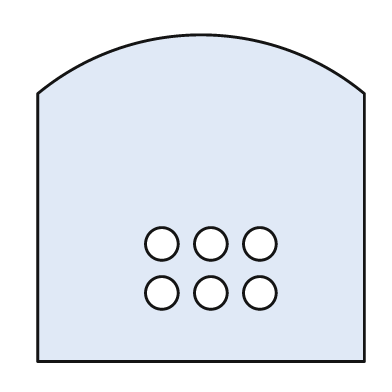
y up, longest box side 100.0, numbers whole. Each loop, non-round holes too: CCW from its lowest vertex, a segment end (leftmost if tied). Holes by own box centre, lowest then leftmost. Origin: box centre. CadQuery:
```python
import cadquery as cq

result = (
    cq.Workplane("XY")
    .moveTo(-50.0, -50.0)
    .lineTo(50.0, -50.0)
    .lineTo(50.0, 32.0)
    .threePointArc((0.0, 50.0), (-50.0, 32.0))
    .close()
    .moveTo(-12.0, -29.0)
    .circle(5.0)
    .moveTo(3.0, -29.0)
    .circle(5.0)
    .moveTo(18.0, -29.0)
    .circle(5.0)
    .moveTo(-12.0, -14.0)
    .circle(5.0)
    .moveTo(3.0, -14.0)
    .circle(5.0)
    .moveTo(18.0, -14.0)
    .circle(5.0)
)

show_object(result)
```